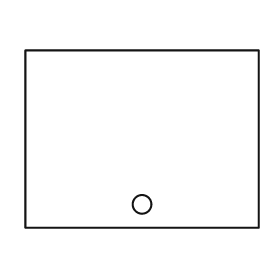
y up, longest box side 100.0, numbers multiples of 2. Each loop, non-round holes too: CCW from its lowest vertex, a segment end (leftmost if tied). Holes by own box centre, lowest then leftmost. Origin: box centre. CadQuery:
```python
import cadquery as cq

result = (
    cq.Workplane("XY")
    .moveTo(-50.0, -38.0)
    .lineTo(50.0, -38.0)
    .lineTo(50.0, 38.0)
    .lineTo(-50.0, 38.0)
    .close()
    .moveTo(0.0, -28.0)
    .circle(4.0)
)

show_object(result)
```